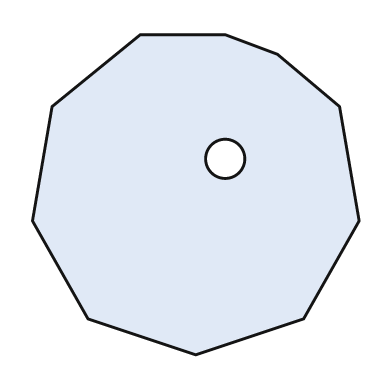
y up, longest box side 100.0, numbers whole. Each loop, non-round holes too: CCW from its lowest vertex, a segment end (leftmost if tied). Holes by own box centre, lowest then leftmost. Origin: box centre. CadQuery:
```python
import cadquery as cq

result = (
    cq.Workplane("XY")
    .moveTo(0.0, -49.0)
    .lineTo(33.0, -38.0)
    .lineTo(50.0, -8.0)
    .lineTo(44.0, 27.0)
    .lineTo(25.0, 43.0)
    .lineTo(9.0, 49.0)
    .lineTo(-17.0, 49.0)
    .lineTo(-44.0, 27.0)
    .lineTo(-50.0, -8.0)
    .lineTo(-33.0, -38.0)
    .close()
    .moveTo(9.0, 11.0)
    .circle(6.0)
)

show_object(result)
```